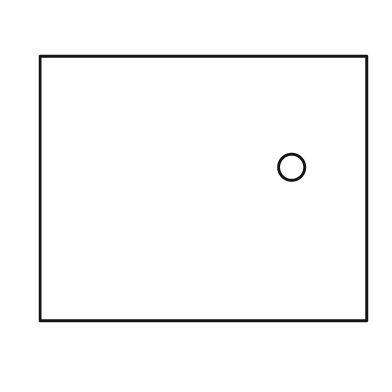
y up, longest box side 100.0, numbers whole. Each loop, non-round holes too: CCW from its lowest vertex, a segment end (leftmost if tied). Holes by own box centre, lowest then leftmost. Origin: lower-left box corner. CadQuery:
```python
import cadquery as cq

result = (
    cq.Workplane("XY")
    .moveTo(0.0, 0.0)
    .lineTo(100.0, 0.0)
    .lineTo(100.0, 81.0)
    .lineTo(0.0, 81.0)
    .close()
    .moveTo(77.0, 47.0)
    .circle(4.0)
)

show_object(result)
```